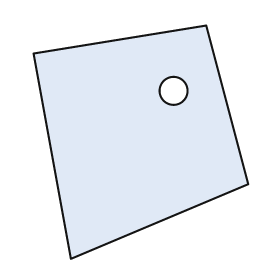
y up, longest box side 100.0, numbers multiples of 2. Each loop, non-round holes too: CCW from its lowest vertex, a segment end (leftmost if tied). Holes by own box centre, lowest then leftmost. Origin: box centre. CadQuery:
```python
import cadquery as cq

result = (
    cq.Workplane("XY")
    .moveTo(-30.0, -50.0)
    .lineTo(46.0, -18.0)
    .lineTo(28.0, 50.0)
    .lineTo(-46.0, 38.0)
    .close()
    .moveTo(14.0, 22.0)
    .circle(6.0)
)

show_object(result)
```